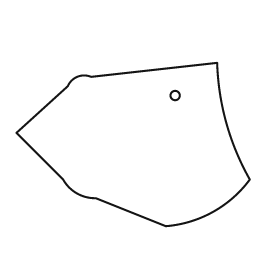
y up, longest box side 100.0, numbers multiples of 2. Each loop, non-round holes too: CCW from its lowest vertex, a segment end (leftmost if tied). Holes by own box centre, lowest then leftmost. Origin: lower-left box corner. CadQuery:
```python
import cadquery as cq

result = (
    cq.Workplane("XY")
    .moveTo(64.0, 0.0)
    .threePointArc((84.0, 6.0), (100.0, 20.0))
    .threePointArc((90.0, 44.0), (86.0, 70.0))
    .lineTo(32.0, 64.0)
    .threePointArc((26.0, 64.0), (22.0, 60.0))
    .lineTo(0.0, 40.0)
    .lineTo(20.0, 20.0)
    .threePointArc((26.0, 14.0), (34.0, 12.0))
    .close()
    .moveTo(68.0, 56.0)
    .circle(2.0)
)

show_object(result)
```